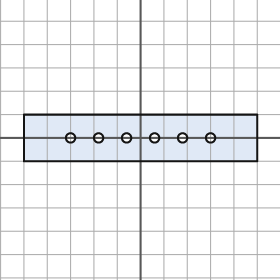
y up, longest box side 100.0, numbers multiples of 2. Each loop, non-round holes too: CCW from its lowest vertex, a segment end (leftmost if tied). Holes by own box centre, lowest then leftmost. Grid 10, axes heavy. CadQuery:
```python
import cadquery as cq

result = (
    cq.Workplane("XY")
    .moveTo(-50.0, -10.0)
    .lineTo(50.0, -10.0)
    .lineTo(50.0, 10.0)
    .lineTo(-50.0, 10.0)
    .close()
    .moveTo(-30.0, 0.0)
    .circle(2.0)
    .moveTo(-18.0, 0.0)
    .circle(2.0)
    .moveTo(-6.0, 0.0)
    .circle(2.0)
    .moveTo(6.0, 0.0)
    .circle(2.0)
    .moveTo(18.0, 0.0)
    .circle(2.0)
    .moveTo(30.0, 0.0)
    .circle(2.0)
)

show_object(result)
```